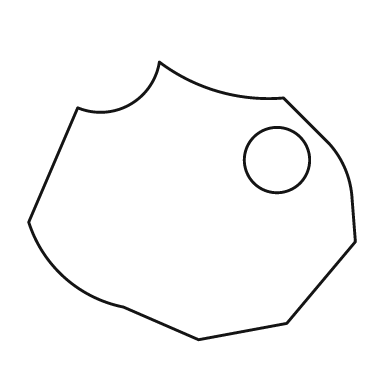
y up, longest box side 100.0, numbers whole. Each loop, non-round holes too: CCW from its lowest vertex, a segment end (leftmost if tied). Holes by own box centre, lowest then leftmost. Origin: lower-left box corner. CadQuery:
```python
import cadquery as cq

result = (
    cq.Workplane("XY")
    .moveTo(52.0, 0.0)
    .lineTo(79.0, 5.0)
    .lineTo(100.0, 30.0)
    .lineTo(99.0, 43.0)
    .threePointArc((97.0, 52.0), (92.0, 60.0))
    .lineTo(78.0, 74.0)
    .threePointArc((58.0, 76.0), (40.0, 85.0))
    .threePointArc((31.0, 72.0), (15.0, 71.0))
    .lineTo(0.0, 36.0)
    .threePointArc((11.0, 19.0), (29.0, 10.0))
    .close()
    .moveTo(76.0, 55.0)
    .circle(10.0)
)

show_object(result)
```